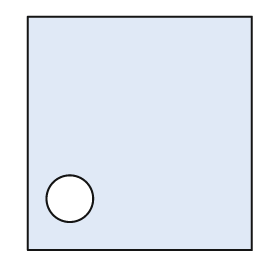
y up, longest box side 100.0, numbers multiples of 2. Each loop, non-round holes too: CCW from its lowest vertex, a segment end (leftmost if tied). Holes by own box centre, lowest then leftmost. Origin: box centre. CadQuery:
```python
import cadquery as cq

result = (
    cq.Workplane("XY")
    .moveTo(-48.0, -50.0)
    .lineTo(48.0, -50.0)
    .lineTo(48.0, 50.0)
    .lineTo(-48.0, 50.0)
    .close()
    .moveTo(-30.0, -28.0)
    .circle(10.0)
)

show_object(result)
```